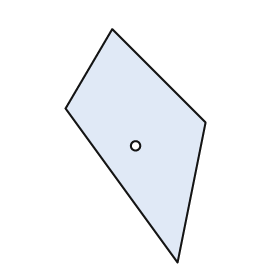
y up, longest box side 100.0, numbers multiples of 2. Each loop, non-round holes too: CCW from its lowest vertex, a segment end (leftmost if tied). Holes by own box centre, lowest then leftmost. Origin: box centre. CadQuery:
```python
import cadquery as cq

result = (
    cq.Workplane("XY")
    .moveTo(18.0, -50.0)
    .lineTo(30.0, 10.0)
    .lineTo(-10.0, 50.0)
    .lineTo(-30.0, 16.0)
    .close()
    .moveTo(0.0, 0.0)
    .circle(2.0)
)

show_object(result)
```